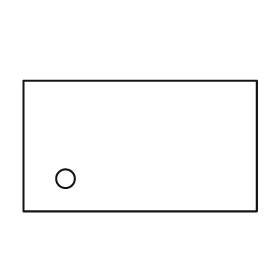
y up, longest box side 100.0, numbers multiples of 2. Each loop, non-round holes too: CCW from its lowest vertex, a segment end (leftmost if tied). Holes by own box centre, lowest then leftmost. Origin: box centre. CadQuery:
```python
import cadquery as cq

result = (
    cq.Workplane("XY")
    .moveTo(-50.0, -28.0)
    .lineTo(50.0, -28.0)
    .lineTo(50.0, 28.0)
    .lineTo(-50.0, 28.0)
    .close()
    .moveTo(-32.0, -14.0)
    .circle(4.0)
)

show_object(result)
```